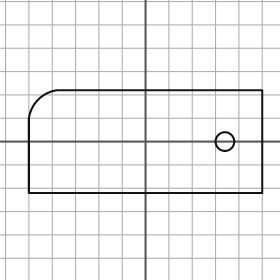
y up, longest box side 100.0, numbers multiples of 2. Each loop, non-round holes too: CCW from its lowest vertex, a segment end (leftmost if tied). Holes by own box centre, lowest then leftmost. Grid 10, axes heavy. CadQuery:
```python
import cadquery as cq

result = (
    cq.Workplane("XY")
    .moveTo(-50.0, -22.0)
    .lineTo(50.0, -22.0)
    .lineTo(50.0, 22.0)
    .lineTo(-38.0, 22.0)
    .threePointArc((-46.0, 18.0), (-50.0, 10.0))
    .close()
    .moveTo(34.0, 0.0)
    .circle(4.0)
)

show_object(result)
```